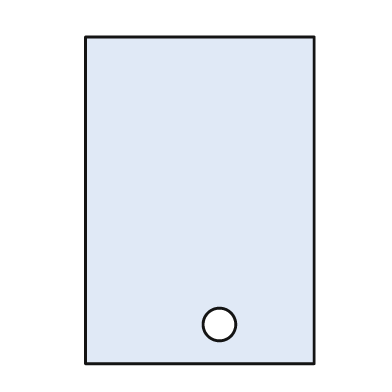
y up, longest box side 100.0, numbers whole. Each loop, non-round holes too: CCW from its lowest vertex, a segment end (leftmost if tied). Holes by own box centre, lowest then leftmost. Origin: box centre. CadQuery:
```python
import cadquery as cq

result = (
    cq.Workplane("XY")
    .moveTo(-35.0, -50.0)
    .lineTo(35.0, -50.0)
    .lineTo(35.0, 50.0)
    .lineTo(-35.0, 50.0)
    .close()
    .moveTo(6.0, -38.0)
    .circle(5.0)
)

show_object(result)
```